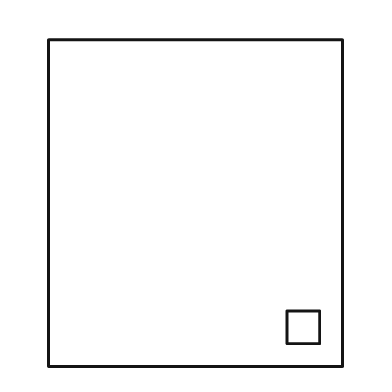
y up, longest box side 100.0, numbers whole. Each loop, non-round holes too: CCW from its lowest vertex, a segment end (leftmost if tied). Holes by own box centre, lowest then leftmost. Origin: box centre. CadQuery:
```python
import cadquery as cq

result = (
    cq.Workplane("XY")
    .moveTo(-45.0, -50.0)
    .lineTo(45.0, -50.0)
    .lineTo(45.0, 50.0)
    .lineTo(-45.0, 50.0)
    .close()
    .moveTo(28.0, -43.0)
    .lineTo(38.0, -43.0)
    .lineTo(38.0, -33.0)
    .lineTo(28.0, -33.0)
    .close()
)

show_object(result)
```